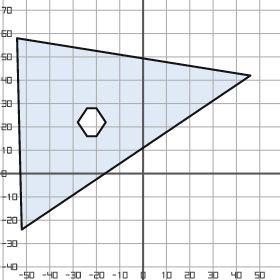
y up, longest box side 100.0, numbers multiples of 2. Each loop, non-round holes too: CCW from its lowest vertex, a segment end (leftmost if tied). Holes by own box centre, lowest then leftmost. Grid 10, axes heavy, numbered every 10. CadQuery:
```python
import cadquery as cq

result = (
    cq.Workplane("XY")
    .moveTo(-52.0, -24.0)
    .lineTo(46.0, 42.0)
    .lineTo(-54.0, 58.0)
    .close()
    .moveTo(-24.0, 16.0)
    .lineTo(-20.0, 16.0)
    .lineTo(-16.0, 22.0)
    .lineTo(-20.0, 28.0)
    .lineTo(-24.0, 28.0)
    .lineTo(-28.0, 22.0)
    .close()
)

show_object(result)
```